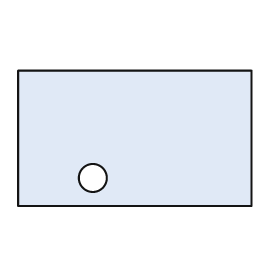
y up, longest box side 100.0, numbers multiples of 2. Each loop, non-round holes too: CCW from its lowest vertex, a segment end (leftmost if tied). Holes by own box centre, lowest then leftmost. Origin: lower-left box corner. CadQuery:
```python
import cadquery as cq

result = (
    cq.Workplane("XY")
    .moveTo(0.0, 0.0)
    .lineTo(100.0, 0.0)
    .lineTo(100.0, 58.0)
    .lineTo(0.0, 58.0)
    .close()
    .moveTo(32.0, 12.0)
    .circle(6.0)
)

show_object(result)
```